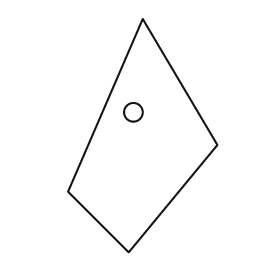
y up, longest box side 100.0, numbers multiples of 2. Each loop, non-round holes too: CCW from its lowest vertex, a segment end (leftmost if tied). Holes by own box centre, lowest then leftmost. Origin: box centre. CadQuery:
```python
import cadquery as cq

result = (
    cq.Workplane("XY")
    .moveTo(-6.0, -50.0)
    .lineTo(32.0, -4.0)
    .lineTo(0.0, 50.0)
    .lineTo(-32.0, -24.0)
    .close()
    .moveTo(-4.0, 10.0)
    .circle(4.0)
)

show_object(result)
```